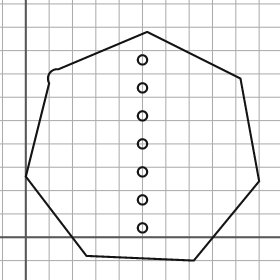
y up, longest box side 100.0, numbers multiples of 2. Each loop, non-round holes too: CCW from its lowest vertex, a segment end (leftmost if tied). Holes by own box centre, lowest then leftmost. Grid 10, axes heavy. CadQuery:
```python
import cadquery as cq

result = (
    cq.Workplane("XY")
    .moveTo(72.0, -10.0)
    .lineTo(100.0, 24.0)
    .lineTo(92.0, 68.0)
    .lineTo(52.0, 88.0)
    .lineTo(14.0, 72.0)
    .threePointArc((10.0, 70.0), (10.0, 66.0))
    .lineTo(0.0, 26.0)
    .lineTo(26.0, -8.0)
    .close()
    .moveTo(50.0, 4.0)
    .circle(2.0)
    .moveTo(50.0, 16.0)
    .circle(2.0)
    .moveTo(50.0, 28.0)
    .circle(2.0)
    .moveTo(50.0, 40.0)
    .circle(2.0)
    .moveTo(50.0, 52.0)
    .circle(2.0)
    .moveTo(50.0, 64.0)
    .circle(2.0)
    .moveTo(50.0, 76.0)
    .circle(2.0)
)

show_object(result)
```